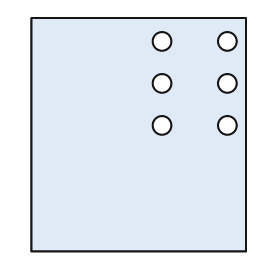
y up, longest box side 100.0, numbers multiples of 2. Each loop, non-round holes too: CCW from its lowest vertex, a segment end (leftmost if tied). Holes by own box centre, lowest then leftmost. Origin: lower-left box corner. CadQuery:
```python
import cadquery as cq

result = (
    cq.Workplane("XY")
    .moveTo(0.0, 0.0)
    .lineTo(92.0, 0.0)
    .lineTo(92.0, 100.0)
    .lineTo(0.0, 100.0)
    .close()
    .moveTo(56.0, 54.0)
    .circle(4.0)
    .moveTo(84.0, 54.0)
    .circle(4.0)
    .moveTo(56.0, 72.0)
    .circle(4.0)
    .moveTo(84.0, 72.0)
    .circle(4.0)
    .moveTo(56.0, 90.0)
    .circle(4.0)
    .moveTo(84.0, 90.0)
    .circle(4.0)
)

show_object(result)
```